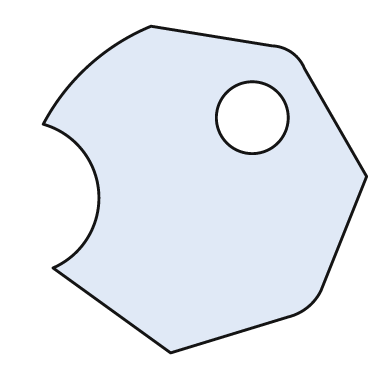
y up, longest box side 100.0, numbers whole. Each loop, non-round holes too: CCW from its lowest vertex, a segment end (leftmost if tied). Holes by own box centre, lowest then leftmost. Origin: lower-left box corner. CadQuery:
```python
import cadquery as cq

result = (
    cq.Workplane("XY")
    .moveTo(39.0, 0.0)
    .lineTo(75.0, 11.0)
    .threePointArc((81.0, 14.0), (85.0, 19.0))
    .lineTo(99.0, 54.0)
    .lineTo(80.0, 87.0)
    .threePointArc((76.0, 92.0), (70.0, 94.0))
    .lineTo(33.0, 100.0)
    .threePointArc((14.0, 88.0), (0.0, 70.0))
    .threePointArc((17.0, 49.0), (3.0, 26.0))
    .close()
    .moveTo(64.0, 72.0)
    .circle(11.0)
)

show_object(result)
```